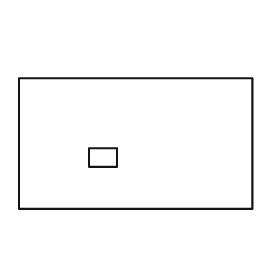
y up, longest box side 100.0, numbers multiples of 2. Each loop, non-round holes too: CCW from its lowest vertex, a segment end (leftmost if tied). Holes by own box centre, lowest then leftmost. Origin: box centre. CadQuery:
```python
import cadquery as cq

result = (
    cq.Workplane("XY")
    .moveTo(-50.0, -28.0)
    .lineTo(50.0, -28.0)
    .lineTo(50.0, 28.0)
    .lineTo(-50.0, 28.0)
    .close()
    .moveTo(-20.0, -10.0)
    .lineTo(-8.0, -10.0)
    .lineTo(-8.0, -2.0)
    .lineTo(-20.0, -2.0)
    .close()
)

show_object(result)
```